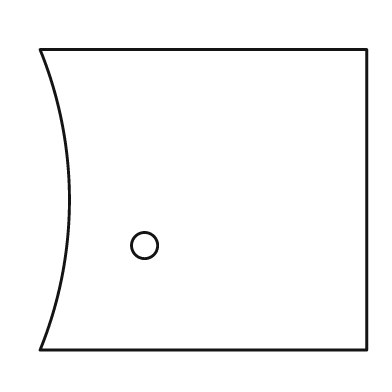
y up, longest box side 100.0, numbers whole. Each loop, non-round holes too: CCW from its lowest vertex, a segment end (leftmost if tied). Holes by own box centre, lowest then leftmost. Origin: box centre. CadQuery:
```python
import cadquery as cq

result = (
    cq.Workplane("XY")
    .moveTo(-50.0, -46.0)
    .lineTo(50.0, -46.0)
    .lineTo(50.0, 46.0)
    .lineTo(-50.0, 46.0)
    .threePointArc((-41.0, 0.0), (-50.0, -46.0))
    .close()
    .moveTo(-18.0, -14.0)
    .circle(4.0)
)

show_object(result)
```